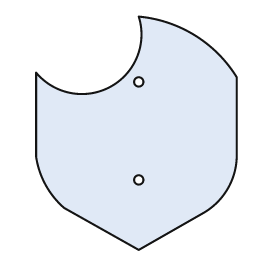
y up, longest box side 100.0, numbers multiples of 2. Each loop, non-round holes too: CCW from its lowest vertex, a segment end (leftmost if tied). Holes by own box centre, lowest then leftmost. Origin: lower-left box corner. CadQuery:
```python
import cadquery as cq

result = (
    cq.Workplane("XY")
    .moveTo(44.0, 0.0)
    .lineTo(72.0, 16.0)
    .threePointArc((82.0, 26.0), (86.0, 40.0))
    .lineTo(86.0, 74.0)
    .threePointArc((68.0, 92.0), (44.0, 100.0))
    .threePointArc((32.0, 70.0), (0.0, 76.0))
    .lineTo(0.0, 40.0)
    .threePointArc((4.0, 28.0), (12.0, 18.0))
    .close()
    .moveTo(44.0, 30.0)
    .circle(2.0)
    .moveTo(44.0, 72.0)
    .circle(2.0)
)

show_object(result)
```